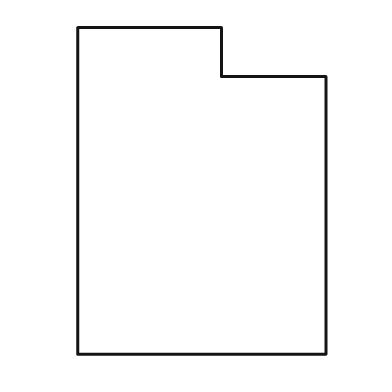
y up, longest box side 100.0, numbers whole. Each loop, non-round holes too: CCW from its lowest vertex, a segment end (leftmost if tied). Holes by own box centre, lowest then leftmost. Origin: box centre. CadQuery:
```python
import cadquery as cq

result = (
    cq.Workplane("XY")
    .moveTo(-38.0, -50.0)
    .lineTo(38.0, -50.0)
    .lineTo(38.0, 35.0)
    .lineTo(6.0, 35.0)
    .lineTo(6.0, 50.0)
    .lineTo(-38.0, 50.0)
    .close()
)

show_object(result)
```